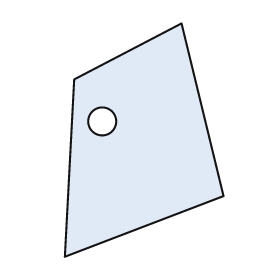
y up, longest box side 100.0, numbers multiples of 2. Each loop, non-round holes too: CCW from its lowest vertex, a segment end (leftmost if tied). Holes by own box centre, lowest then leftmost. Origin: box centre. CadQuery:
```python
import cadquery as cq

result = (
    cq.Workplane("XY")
    .moveTo(-34.0, -50.0)
    .lineTo(34.0, -24.0)
    .lineTo(16.0, 50.0)
    .lineTo(-30.0, 26.0)
    .close()
    .moveTo(-18.0, 8.0)
    .circle(6.0)
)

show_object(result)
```